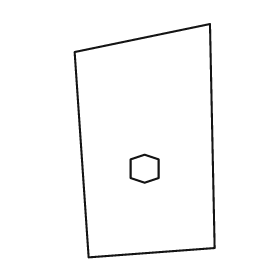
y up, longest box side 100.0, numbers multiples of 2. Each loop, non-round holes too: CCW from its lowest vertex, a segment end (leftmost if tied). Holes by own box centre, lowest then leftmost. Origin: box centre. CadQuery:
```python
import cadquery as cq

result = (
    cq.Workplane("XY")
    .moveTo(-24.0, -50.0)
    .lineTo(30.0, -46.0)
    .lineTo(28.0, 50.0)
    .lineTo(-30.0, 38.0)
    .close()
    .moveTo(0.0, -18.0)
    .lineTo(6.0, -16.0)
    .lineTo(6.0, -8.0)
    .lineTo(0.0, -6.0)
    .lineTo(-6.0, -8.0)
    .lineTo(-6.0, -16.0)
    .close()
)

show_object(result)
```